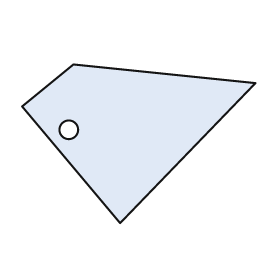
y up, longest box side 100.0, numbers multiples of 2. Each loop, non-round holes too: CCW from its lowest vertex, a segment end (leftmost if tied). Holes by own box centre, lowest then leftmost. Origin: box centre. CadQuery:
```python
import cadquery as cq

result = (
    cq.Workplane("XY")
    .moveTo(-8.0, -34.0)
    .lineTo(50.0, 26.0)
    .lineTo(-28.0, 34.0)
    .lineTo(-50.0, 16.0)
    .close()
    .moveTo(-30.0, 6.0)
    .circle(4.0)
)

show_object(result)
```